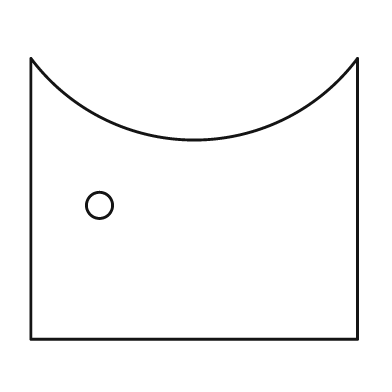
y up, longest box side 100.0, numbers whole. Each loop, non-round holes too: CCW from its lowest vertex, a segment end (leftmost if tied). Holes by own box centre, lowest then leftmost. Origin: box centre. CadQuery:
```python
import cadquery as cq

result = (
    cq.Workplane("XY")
    .moveTo(-50.0, -43.0)
    .lineTo(50.0, -43.0)
    .lineTo(50.0, 43.0)
    .threePointArc((0.0, 18.0), (-50.0, 43.0))
    .close()
    .moveTo(-29.0, -2.0)
    .circle(4.0)
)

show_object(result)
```